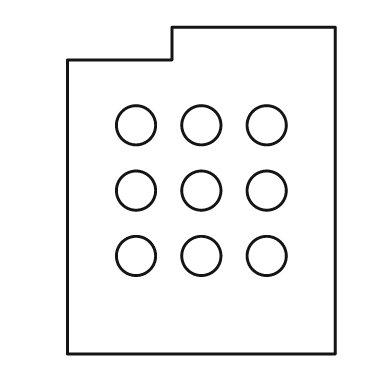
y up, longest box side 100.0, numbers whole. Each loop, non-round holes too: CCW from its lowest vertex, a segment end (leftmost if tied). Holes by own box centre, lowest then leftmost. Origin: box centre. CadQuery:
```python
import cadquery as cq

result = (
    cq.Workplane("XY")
    .moveTo(-41.0, -50.0)
    .lineTo(41.0, -50.0)
    .lineTo(41.0, 50.0)
    .lineTo(-9.0, 50.0)
    .lineTo(-9.0, 40.0)
    .lineTo(-41.0, 40.0)
    .close()
    .moveTo(-20.0, -20.0)
    .circle(6.0)
    .moveTo(0.0, -20.0)
    .circle(6.0)
    .moveTo(20.0, -20.0)
    .circle(6.0)
    .moveTo(-20.0, 0.0)
    .circle(6.0)
    .moveTo(0.0, 0.0)
    .circle(6.0)
    .moveTo(20.0, 0.0)
    .circle(6.0)
    .moveTo(-20.0, 20.0)
    .circle(6.0)
    .moveTo(0.0, 20.0)
    .circle(6.0)
    .moveTo(20.0, 20.0)
    .circle(6.0)
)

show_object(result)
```